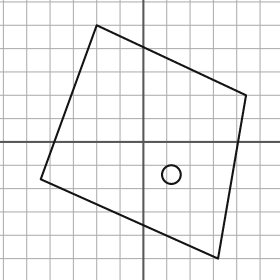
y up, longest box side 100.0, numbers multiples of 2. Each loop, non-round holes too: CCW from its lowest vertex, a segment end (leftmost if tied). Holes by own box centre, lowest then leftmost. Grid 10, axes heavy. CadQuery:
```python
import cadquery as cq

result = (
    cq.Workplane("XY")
    .moveTo(32.0, -50.0)
    .lineTo(44.0, 20.0)
    .lineTo(-20.0, 50.0)
    .lineTo(-44.0, -16.0)
    .close()
    .moveTo(12.0, -14.0)
    .circle(4.0)
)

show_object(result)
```